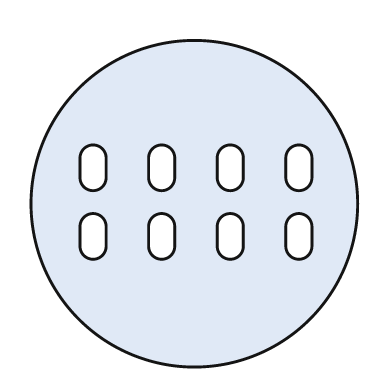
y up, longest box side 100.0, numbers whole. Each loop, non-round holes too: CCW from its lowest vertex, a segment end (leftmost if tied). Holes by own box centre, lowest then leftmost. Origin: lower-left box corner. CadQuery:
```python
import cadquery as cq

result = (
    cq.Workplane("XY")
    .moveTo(50.0, 50.0)
    .circle(50.0)
    .moveTo(15.0, 37.0)
    .threePointArc((19.0, 33.0), (23.0, 37.0))
    .lineTo(23.0, 43.0)
    .threePointArc((19.0, 47.0), (15.0, 43.0))
    .close()
    .moveTo(36.0, 37.0)
    .threePointArc((40.0, 33.0), (44.0, 37.0))
    .lineTo(44.0, 43.0)
    .threePointArc((40.0, 47.0), (36.0, 43.0))
    .close()
    .moveTo(57.0, 37.0)
    .threePointArc((61.0, 33.0), (65.0, 37.0))
    .lineTo(65.0, 43.0)
    .threePointArc((61.0, 47.0), (57.0, 43.0))
    .close()
    .moveTo(78.0, 37.0)
    .threePointArc((82.0, 33.0), (86.0, 37.0))
    .lineTo(86.0, 43.0)
    .threePointArc((82.0, 47.0), (78.0, 43.0))
    .close()
    .moveTo(15.0, 58.0)
    .threePointArc((19.0, 54.0), (23.0, 58.0))
    .lineTo(23.0, 64.0)
    .threePointArc((19.0, 68.0), (15.0, 64.0))
    .close()
    .moveTo(36.0, 58.0)
    .threePointArc((40.0, 54.0), (44.0, 58.0))
    .lineTo(44.0, 64.0)
    .threePointArc((40.0, 68.0), (36.0, 64.0))
    .close()
    .moveTo(57.0, 58.0)
    .threePointArc((61.0, 54.0), (65.0, 58.0))
    .lineTo(65.0, 64.0)
    .threePointArc((61.0, 68.0), (57.0, 64.0))
    .close()
    .moveTo(78.0, 58.0)
    .threePointArc((82.0, 54.0), (86.0, 58.0))
    .lineTo(86.0, 64.0)
    .threePointArc((82.0, 68.0), (78.0, 64.0))
    .close()
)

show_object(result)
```